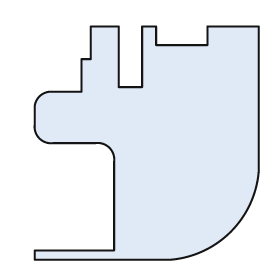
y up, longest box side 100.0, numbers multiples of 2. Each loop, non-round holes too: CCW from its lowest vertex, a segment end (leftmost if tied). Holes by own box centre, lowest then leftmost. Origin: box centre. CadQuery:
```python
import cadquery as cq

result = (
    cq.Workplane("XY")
    .moveTo(-48.0, -50.0)
    .lineTo(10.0, -50.0)
    .threePointArc((36.0, -38.0), (48.0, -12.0))
    .lineTo(48.0, 50.0)
    .lineTo(26.0, 50.0)
    .lineTo(26.0, 42.0)
    .lineTo(4.0, 42.0)
    .lineTo(4.0, 50.0)
    .lineTo(-2.0, 50.0)
    .lineTo(-2.0, 24.0)
    .lineTo(-12.0, 24.0)
    .lineTo(-12.0, 50.0)
    .lineTo(-24.0, 50.0)
    .lineTo(-24.0, 36.0)
    .lineTo(-28.0, 36.0)
    .lineTo(-28.0, 22.0)
    .lineTo(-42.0, 22.0)
    .threePointArc((-46.0, 20.0), (-48.0, 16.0))
    .lineTo(-48.0, 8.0)
    .threePointArc((-46.0, 2.0), (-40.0, 0.0))
    .lineTo(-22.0, 0.0)
    .threePointArc((-16.0, -2.0), (-14.0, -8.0))
    .lineTo(-14.0, -46.0)
    .lineTo(-48.0, -46.0)
    .close()
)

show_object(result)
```